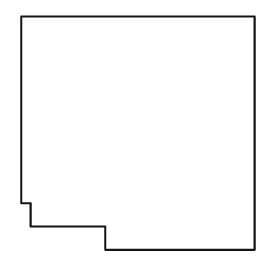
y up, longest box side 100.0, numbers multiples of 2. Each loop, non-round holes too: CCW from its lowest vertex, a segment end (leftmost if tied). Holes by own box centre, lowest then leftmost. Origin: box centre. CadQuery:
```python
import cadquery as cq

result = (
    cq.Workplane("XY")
    .moveTo(-14.0, -50.0)
    .lineTo(50.0, -50.0)
    .lineTo(50.0, 50.0)
    .lineTo(-50.0, 50.0)
    .lineTo(-50.0, -30.0)
    .lineTo(-46.0, -30.0)
    .lineTo(-46.0, -40.0)
    .lineTo(-14.0, -40.0)
    .close()
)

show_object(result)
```